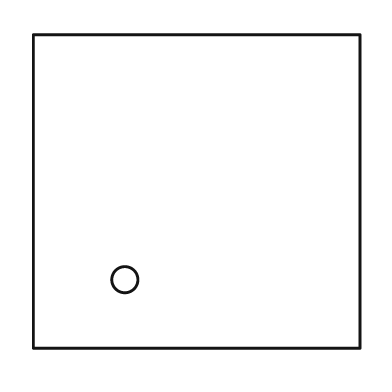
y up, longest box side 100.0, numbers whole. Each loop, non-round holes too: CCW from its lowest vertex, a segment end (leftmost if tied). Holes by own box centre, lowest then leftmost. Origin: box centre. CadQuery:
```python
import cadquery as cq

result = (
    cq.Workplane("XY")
    .moveTo(-50.0, -48.0)
    .lineTo(50.0, -48.0)
    .lineTo(50.0, 48.0)
    .lineTo(-50.0, 48.0)
    .close()
    .moveTo(-22.0, -27.0)
    .circle(4.0)
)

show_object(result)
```